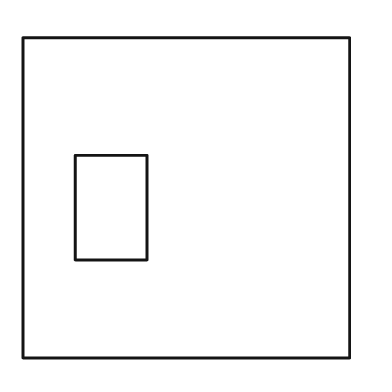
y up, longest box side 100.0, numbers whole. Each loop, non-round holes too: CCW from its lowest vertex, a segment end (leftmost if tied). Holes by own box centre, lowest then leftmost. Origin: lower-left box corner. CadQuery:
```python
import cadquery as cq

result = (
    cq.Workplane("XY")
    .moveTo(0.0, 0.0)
    .lineTo(100.0, 0.0)
    .lineTo(100.0, 98.0)
    .lineTo(0.0, 98.0)
    .close()
    .moveTo(16.0, 30.0)
    .lineTo(38.0, 30.0)
    .lineTo(38.0, 62.0)
    .lineTo(16.0, 62.0)
    .close()
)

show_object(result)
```